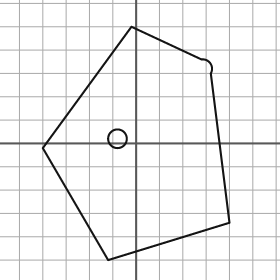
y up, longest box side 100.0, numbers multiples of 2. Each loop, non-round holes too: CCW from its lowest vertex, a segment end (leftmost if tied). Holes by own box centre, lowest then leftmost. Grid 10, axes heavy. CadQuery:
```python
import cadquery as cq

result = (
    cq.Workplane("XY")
    .moveTo(-12.0, -50.0)
    .lineTo(40.0, -34.0)
    .lineTo(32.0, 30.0)
    .threePointArc((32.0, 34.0), (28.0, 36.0))
    .lineTo(-2.0, 50.0)
    .lineTo(-40.0, -2.0)
    .close()
    .moveTo(-8.0, 2.0)
    .circle(4.0)
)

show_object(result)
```